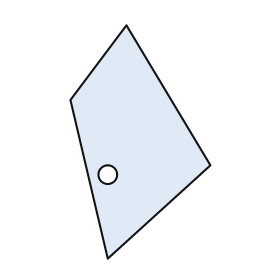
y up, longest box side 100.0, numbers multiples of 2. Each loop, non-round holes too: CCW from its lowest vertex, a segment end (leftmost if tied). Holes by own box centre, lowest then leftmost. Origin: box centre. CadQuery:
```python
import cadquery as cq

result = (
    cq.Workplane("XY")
    .moveTo(-14.0, -50.0)
    .lineTo(30.0, -10.0)
    .lineTo(-6.0, 50.0)
    .lineTo(-30.0, 18.0)
    .close()
    .moveTo(-14.0, -14.0)
    .circle(4.0)
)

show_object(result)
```